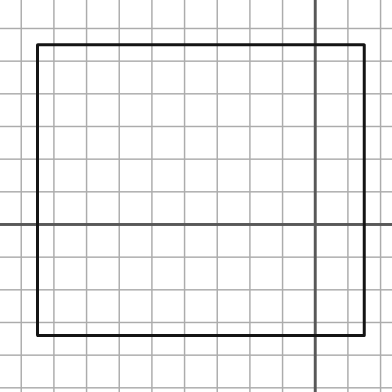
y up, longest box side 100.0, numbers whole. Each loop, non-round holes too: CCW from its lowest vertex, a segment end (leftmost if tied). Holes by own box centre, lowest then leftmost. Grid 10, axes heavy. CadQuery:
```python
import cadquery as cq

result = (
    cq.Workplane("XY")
    .moveTo(-85.0, -34.0)
    .lineTo(15.0, -34.0)
    .lineTo(15.0, 55.0)
    .lineTo(-85.0, 55.0)
    .close()
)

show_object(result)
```